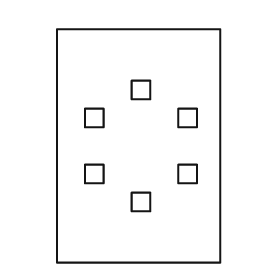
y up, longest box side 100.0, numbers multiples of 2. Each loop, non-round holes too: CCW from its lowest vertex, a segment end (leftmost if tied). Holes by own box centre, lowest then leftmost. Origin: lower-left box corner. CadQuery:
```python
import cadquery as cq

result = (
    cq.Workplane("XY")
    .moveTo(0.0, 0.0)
    .lineTo(70.0, 0.0)
    .lineTo(70.0, 100.0)
    .lineTo(0.0, 100.0)
    .close()
    .moveTo(32.0, 22.0)
    .lineTo(40.0, 22.0)
    .lineTo(40.0, 30.0)
    .lineTo(32.0, 30.0)
    .close()
    .moveTo(12.0, 34.0)
    .lineTo(20.0, 34.0)
    .lineTo(20.0, 42.0)
    .lineTo(12.0, 42.0)
    .close()
    .moveTo(52.0, 34.0)
    .lineTo(60.0, 34.0)
    .lineTo(60.0, 42.0)
    .lineTo(52.0, 42.0)
    .close()
    .moveTo(12.0, 58.0)
    .lineTo(20.0, 58.0)
    .lineTo(20.0, 66.0)
    .lineTo(12.0, 66.0)
    .close()
    .moveTo(52.0, 58.0)
    .lineTo(60.0, 58.0)
    .lineTo(60.0, 66.0)
    .lineTo(52.0, 66.0)
    .close()
    .moveTo(32.0, 70.0)
    .lineTo(40.0, 70.0)
    .lineTo(40.0, 78.0)
    .lineTo(32.0, 78.0)
    .close()
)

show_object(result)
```